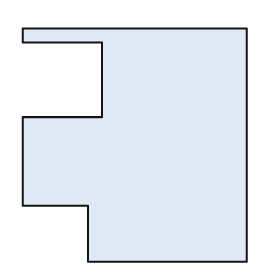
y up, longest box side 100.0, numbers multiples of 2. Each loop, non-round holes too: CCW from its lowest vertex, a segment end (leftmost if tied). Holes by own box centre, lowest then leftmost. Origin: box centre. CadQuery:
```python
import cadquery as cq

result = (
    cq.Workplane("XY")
    .moveTo(-20.0, -50.0)
    .lineTo(48.0, -50.0)
    .lineTo(48.0, 50.0)
    .lineTo(-48.0, 50.0)
    .lineTo(-48.0, 44.0)
    .lineTo(-14.0, 44.0)
    .lineTo(-14.0, 12.0)
    .lineTo(-48.0, 12.0)
    .lineTo(-48.0, -26.0)
    .lineTo(-20.0, -26.0)
    .close()
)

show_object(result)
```